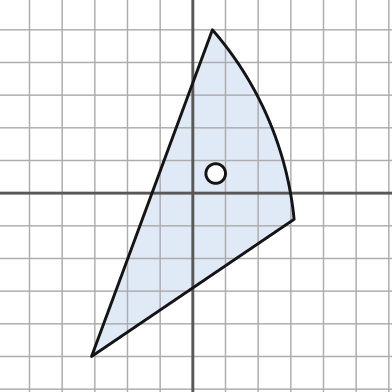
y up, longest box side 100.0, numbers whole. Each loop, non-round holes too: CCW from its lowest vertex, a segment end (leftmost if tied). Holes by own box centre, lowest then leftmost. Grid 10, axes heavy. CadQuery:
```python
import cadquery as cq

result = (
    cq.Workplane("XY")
    .moveTo(-31.0, -50.0)
    .lineTo(31.0, -8.0)
    .threePointArc((23.0, 23.0), (6.0, 50.0))
    .close()
    .moveTo(7.0, 6.0)
    .circle(3.0)
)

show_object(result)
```